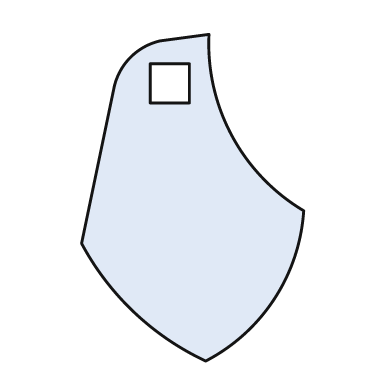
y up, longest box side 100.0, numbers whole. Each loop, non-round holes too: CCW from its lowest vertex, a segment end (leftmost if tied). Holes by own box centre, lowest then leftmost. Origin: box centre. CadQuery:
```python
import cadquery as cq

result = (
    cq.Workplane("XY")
    .moveTo(4.0, -50.0)
    .threePointArc((25.0, -31.0), (34.0, -4.0))
    .threePointArc((12.0, 19.0), (5.0, 50.0))
    .lineTo(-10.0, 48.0)
    .threePointArc((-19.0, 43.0), (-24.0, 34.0))
    .lineTo(-34.0, -14.0)
    .threePointArc((-18.0, -35.0), (4.0, -50.0))
    .close()
    .moveTo(-13.0, 29.0)
    .lineTo(-1.0, 29.0)
    .lineTo(-1.0, 41.0)
    .lineTo(-13.0, 41.0)
    .close()
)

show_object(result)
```